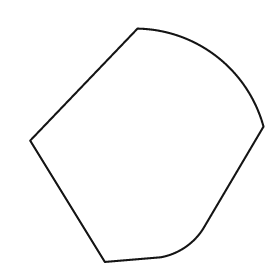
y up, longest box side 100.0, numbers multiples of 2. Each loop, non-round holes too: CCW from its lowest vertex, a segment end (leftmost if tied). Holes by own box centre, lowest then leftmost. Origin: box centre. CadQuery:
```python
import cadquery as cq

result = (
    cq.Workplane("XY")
    .moveTo(-18.0, -50.0)
    .lineTo(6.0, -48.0)
    .threePointArc((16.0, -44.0), (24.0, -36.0))
    .lineTo(50.0, 8.0)
    .threePointArc((30.0, 38.0), (-4.0, 50.0))
    .lineTo(-50.0, 2.0)
    .close()
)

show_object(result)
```